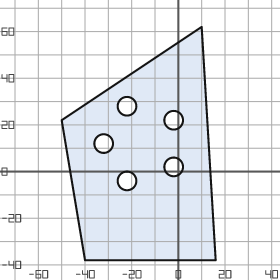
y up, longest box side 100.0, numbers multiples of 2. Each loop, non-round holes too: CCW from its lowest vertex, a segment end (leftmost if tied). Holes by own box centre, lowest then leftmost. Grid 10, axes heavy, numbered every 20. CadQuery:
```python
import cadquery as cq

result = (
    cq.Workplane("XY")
    .moveTo(-40.0, -38.0)
    .lineTo(16.0, -38.0)
    .lineTo(10.0, 62.0)
    .lineTo(-50.0, 22.0)
    .close()
    .moveTo(-22.0, -4.0)
    .circle(4.0)
    .moveTo(-2.0, 2.0)
    .circle(4.0)
    .moveTo(-32.0, 12.0)
    .circle(4.0)
    .moveTo(-2.0, 22.0)
    .circle(4.0)
    .moveTo(-22.0, 28.0)
    .circle(4.0)
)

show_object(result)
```